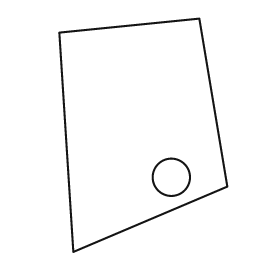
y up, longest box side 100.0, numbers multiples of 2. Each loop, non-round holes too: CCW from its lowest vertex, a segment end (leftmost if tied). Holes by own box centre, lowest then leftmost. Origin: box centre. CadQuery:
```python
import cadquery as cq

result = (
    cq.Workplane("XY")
    .moveTo(-30.0, -50.0)
    .lineTo(36.0, -22.0)
    .lineTo(24.0, 50.0)
    .lineTo(-36.0, 44.0)
    .close()
    .moveTo(12.0, -18.0)
    .circle(8.0)
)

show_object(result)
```